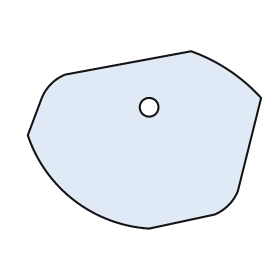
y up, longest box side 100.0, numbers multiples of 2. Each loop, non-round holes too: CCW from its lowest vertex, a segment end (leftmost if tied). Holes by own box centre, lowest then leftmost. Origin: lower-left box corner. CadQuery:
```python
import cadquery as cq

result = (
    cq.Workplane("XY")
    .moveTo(52.0, 0.0)
    .lineTo(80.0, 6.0)
    .threePointArc((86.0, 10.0), (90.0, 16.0))
    .lineTo(100.0, 56.0)
    .threePointArc((86.0, 68.0), (70.0, 76.0))
    .lineTo(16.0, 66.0)
    .threePointArc((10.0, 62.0), (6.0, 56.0))
    .lineTo(0.0, 40.0)
    .threePointArc((20.0, 12.0), (52.0, 0.0))
    .close()
    .moveTo(52.0, 52.0)
    .circle(4.0)
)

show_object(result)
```